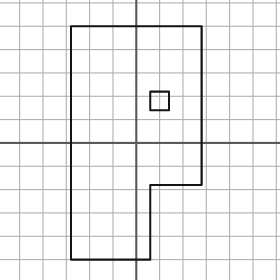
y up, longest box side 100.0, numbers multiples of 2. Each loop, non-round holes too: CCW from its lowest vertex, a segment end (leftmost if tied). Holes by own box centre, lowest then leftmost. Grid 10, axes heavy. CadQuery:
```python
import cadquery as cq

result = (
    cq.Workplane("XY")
    .moveTo(-28.0, -50.0)
    .lineTo(6.0, -50.0)
    .lineTo(6.0, -18.0)
    .lineTo(28.0, -18.0)
    .lineTo(28.0, 50.0)
    .lineTo(-28.0, 50.0)
    .close()
    .moveTo(6.0, 14.0)
    .lineTo(14.0, 14.0)
    .lineTo(14.0, 22.0)
    .lineTo(6.0, 22.0)
    .close()
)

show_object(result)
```